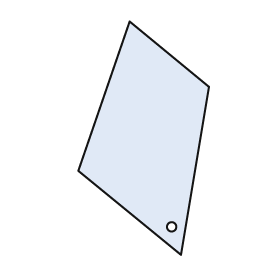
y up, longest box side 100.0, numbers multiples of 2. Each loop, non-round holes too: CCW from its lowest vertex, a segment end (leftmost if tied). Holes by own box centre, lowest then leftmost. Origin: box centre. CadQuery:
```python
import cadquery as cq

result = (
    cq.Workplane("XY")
    .moveTo(16.0, -50.0)
    .lineTo(28.0, 22.0)
    .lineTo(-6.0, 50.0)
    .lineTo(-28.0, -14.0)
    .close()
    .moveTo(12.0, -38.0)
    .circle(2.0)
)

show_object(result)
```